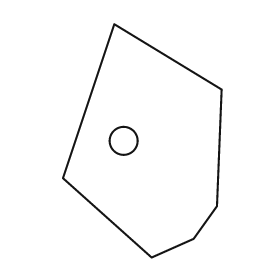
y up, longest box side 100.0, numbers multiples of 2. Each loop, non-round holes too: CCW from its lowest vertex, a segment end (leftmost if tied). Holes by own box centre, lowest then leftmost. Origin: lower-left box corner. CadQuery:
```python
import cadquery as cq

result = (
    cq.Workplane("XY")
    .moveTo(38.0, 0.0)
    .lineTo(56.0, 8.0)
    .lineTo(66.0, 22.0)
    .lineTo(68.0, 72.0)
    .lineTo(22.0, 100.0)
    .lineTo(0.0, 34.0)
    .close()
    .moveTo(26.0, 50.0)
    .circle(6.0)
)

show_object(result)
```